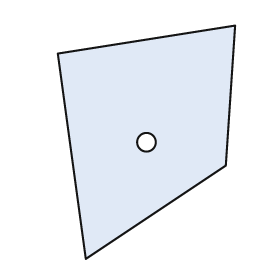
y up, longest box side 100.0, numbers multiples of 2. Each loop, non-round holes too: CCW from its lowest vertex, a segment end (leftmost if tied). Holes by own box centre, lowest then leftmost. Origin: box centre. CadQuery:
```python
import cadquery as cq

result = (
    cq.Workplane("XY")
    .moveTo(-26.0, -50.0)
    .lineTo(34.0, -10.0)
    .lineTo(38.0, 50.0)
    .lineTo(-38.0, 38.0)
    .close()
    .moveTo(0.0, 0.0)
    .circle(4.0)
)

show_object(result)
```